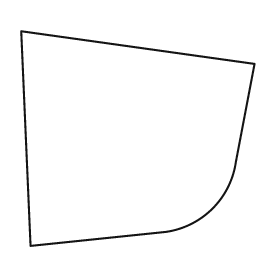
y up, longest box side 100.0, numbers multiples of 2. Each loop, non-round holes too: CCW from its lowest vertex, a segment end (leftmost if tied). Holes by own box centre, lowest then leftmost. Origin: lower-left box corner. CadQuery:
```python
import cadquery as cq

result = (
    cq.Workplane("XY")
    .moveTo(4.0, 0.0)
    .lineTo(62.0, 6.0)
    .threePointArc((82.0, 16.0), (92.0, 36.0))
    .lineTo(100.0, 78.0)
    .lineTo(0.0, 92.0)
    .close()
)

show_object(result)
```